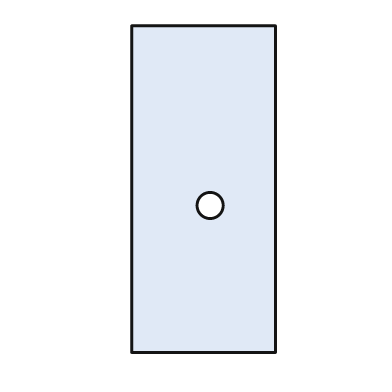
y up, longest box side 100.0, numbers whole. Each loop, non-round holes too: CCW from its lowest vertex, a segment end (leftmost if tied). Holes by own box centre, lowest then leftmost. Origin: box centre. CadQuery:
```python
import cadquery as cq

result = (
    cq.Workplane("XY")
    .moveTo(-22.0, -50.0)
    .lineTo(22.0, -50.0)
    .lineTo(22.0, 50.0)
    .lineTo(-22.0, 50.0)
    .close()
    .moveTo(2.0, -5.0)
    .circle(4.0)
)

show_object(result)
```